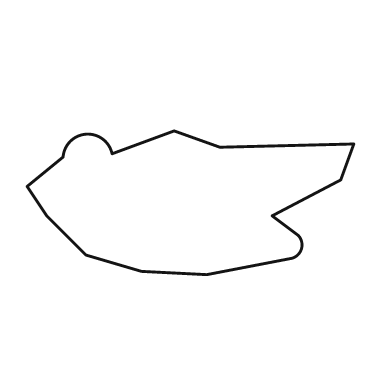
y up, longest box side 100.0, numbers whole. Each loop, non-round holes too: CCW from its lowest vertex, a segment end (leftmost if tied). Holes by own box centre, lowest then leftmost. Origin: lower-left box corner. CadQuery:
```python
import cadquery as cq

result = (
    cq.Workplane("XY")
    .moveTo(55.0, 0.0)
    .lineTo(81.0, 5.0)
    .threePointArc((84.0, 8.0), (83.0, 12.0))
    .lineTo(75.0, 18.0)
    .lineTo(96.0, 29.0)
    .lineTo(100.0, 40.0)
    .lineTo(59.0, 39.0)
    .lineTo(45.0, 44.0)
    .lineTo(26.0, 37.0)
    .threePointArc((18.0, 43.0), (11.0, 36.0))
    .lineTo(0.0, 27.0)
    .lineTo(6.0, 18.0)
    .lineTo(18.0, 6.0)
    .lineTo(35.0, 1.0)
    .close()
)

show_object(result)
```